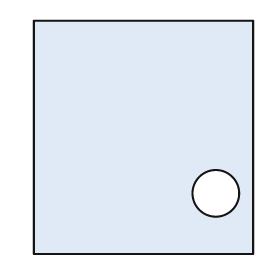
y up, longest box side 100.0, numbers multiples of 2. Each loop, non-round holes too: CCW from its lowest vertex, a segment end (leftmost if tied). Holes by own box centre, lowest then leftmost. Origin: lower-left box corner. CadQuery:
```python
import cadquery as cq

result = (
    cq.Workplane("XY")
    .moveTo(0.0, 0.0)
    .lineTo(94.0, 0.0)
    .lineTo(94.0, 100.0)
    .lineTo(0.0, 100.0)
    .close()
    .moveTo(78.0, 26.0)
    .circle(10.0)
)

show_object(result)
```